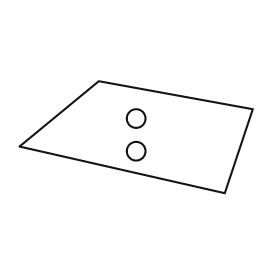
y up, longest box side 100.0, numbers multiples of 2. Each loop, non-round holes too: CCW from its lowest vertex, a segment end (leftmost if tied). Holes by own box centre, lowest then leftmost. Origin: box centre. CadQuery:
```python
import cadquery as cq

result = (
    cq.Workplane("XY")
    .moveTo(38.0, -24.0)
    .lineTo(50.0, 12.0)
    .lineTo(-16.0, 24.0)
    .lineTo(-50.0, -4.0)
    .close()
    .moveTo(0.0, -6.0)
    .circle(4.0)
    .moveTo(0.0, 8.0)
    .circle(4.0)
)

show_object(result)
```